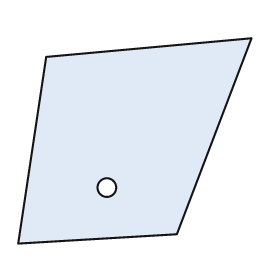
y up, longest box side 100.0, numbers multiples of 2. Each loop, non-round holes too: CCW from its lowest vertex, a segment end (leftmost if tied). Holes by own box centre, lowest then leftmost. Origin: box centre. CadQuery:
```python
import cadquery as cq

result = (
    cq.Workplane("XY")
    .moveTo(-50.0, -44.0)
    .lineTo(18.0, -40.0)
    .lineTo(50.0, 44.0)
    .lineTo(-38.0, 36.0)
    .close()
    .moveTo(-12.0, -20.0)
    .circle(4.0)
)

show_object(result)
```